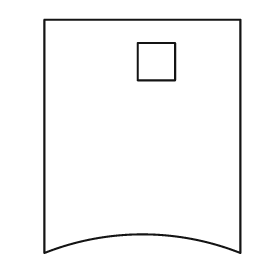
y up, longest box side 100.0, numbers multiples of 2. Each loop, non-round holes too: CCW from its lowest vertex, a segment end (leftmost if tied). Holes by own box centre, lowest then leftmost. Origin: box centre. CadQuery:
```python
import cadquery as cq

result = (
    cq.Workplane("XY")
    .moveTo(-42.0, -50.0)
    .threePointArc((0.0, -42.0), (42.0, -50.0))
    .lineTo(42.0, 50.0)
    .lineTo(-42.0, 50.0)
    .close()
    .moveTo(-2.0, 24.0)
    .lineTo(14.0, 24.0)
    .lineTo(14.0, 40.0)
    .lineTo(-2.0, 40.0)
    .close()
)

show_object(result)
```